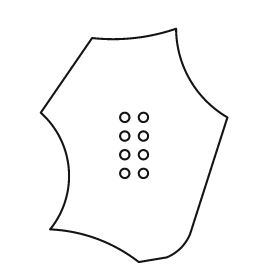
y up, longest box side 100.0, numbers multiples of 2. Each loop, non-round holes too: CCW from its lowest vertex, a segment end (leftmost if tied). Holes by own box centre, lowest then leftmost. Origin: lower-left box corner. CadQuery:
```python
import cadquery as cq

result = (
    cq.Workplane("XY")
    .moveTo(42.0, 0.0)
    .lineTo(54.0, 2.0)
    .threePointArc((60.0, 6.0), (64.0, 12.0))
    .lineTo(80.0, 62.0)
    .threePointArc((64.0, 78.0), (58.0, 100.0))
    .threePointArc((40.0, 96.0), (22.0, 96.0))
    .lineTo(0.0, 64.0)
    .threePointArc((12.0, 40.0), (4.0, 14.0))
    .threePointArc((24.0, 10.0), (42.0, 0.0))
    .close()
    .moveTo(36.0, 38.0)
    .circle(2.0)
    .moveTo(44.0, 38.0)
    .circle(2.0)
    .moveTo(36.0, 46.0)
    .circle(2.0)
    .moveTo(44.0, 46.0)
    .circle(2.0)
    .moveTo(36.0, 54.0)
    .circle(2.0)
    .moveTo(44.0, 54.0)
    .circle(2.0)
    .moveTo(36.0, 62.0)
    .circle(2.0)
    .moveTo(44.0, 62.0)
    .circle(2.0)
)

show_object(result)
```